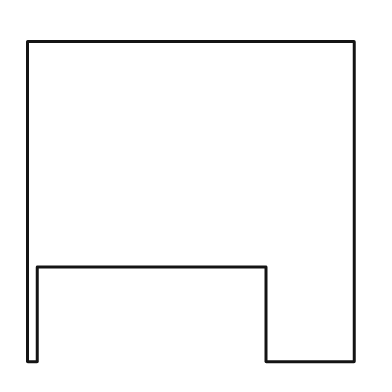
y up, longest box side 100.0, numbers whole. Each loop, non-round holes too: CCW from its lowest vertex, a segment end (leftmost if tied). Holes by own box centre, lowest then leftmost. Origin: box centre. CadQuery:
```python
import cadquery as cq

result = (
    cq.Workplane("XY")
    .moveTo(-50.0, -49.0)
    .lineTo(-47.0, -49.0)
    .lineTo(-47.0, -20.0)
    .lineTo(23.0, -20.0)
    .lineTo(23.0, -49.0)
    .lineTo(50.0, -49.0)
    .lineTo(50.0, 49.0)
    .lineTo(-50.0, 49.0)
    .close()
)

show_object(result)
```